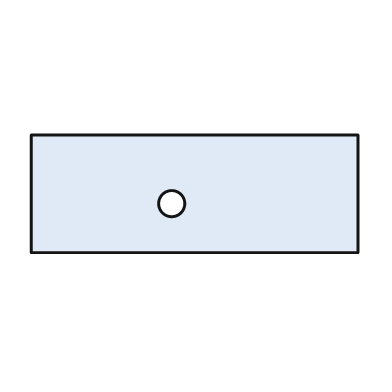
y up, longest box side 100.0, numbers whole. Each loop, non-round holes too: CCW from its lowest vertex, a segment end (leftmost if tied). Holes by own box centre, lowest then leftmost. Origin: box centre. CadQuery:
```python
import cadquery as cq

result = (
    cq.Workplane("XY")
    .moveTo(-50.0, -18.0)
    .lineTo(50.0, -18.0)
    .lineTo(50.0, 18.0)
    .lineTo(-50.0, 18.0)
    .close()
    .moveTo(-7.0, -3.0)
    .circle(4.0)
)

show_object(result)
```